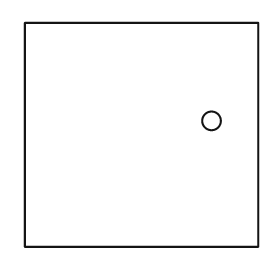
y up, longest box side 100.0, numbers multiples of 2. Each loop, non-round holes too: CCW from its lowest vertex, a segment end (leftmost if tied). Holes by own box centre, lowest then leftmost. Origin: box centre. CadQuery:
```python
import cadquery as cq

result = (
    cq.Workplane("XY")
    .moveTo(-50.0, -48.0)
    .lineTo(50.0, -48.0)
    .lineTo(50.0, 48.0)
    .lineTo(-50.0, 48.0)
    .close()
    .moveTo(30.0, 6.0)
    .circle(4.0)
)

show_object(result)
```